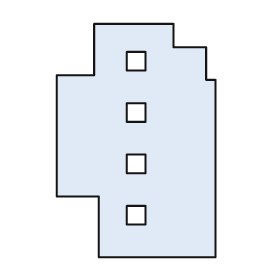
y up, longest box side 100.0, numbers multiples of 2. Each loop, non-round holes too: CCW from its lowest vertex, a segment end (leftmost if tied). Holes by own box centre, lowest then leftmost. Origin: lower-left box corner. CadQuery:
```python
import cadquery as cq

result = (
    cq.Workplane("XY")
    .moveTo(18.0, 0.0)
    .lineTo(68.0, 0.0)
    .lineTo(68.0, 76.0)
    .lineTo(64.0, 76.0)
    .lineTo(64.0, 90.0)
    .lineTo(50.0, 90.0)
    .lineTo(50.0, 100.0)
    .lineTo(16.0, 100.0)
    .lineTo(16.0, 78.0)
    .lineTo(0.0, 78.0)
    .lineTo(0.0, 26.0)
    .lineTo(18.0, 26.0)
    .close()
    .moveTo(30.0, 14.0)
    .lineTo(38.0, 14.0)
    .lineTo(38.0, 22.0)
    .lineTo(30.0, 22.0)
    .close()
    .moveTo(30.0, 36.0)
    .lineTo(38.0, 36.0)
    .lineTo(38.0, 44.0)
    .lineTo(30.0, 44.0)
    .close()
    .moveTo(30.0, 58.0)
    .lineTo(38.0, 58.0)
    .lineTo(38.0, 66.0)
    .lineTo(30.0, 66.0)
    .close()
    .moveTo(30.0, 80.0)
    .lineTo(38.0, 80.0)
    .lineTo(38.0, 88.0)
    .lineTo(30.0, 88.0)
    .close()
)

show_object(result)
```